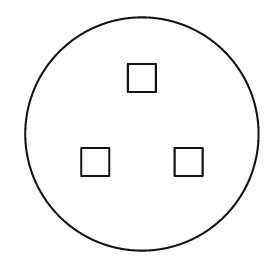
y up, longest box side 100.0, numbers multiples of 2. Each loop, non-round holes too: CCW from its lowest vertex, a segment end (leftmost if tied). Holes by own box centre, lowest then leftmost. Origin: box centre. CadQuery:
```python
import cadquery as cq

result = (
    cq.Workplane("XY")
    .moveTo(0.0, 0.0)
    .circle(50.0)
    .moveTo(-26.0, -18.0)
    .lineTo(-14.0, -18.0)
    .lineTo(-14.0, -6.0)
    .lineTo(-26.0, -6.0)
    .close()
    .moveTo(14.0, -18.0)
    .lineTo(26.0, -18.0)
    .lineTo(26.0, -6.0)
    .lineTo(14.0, -6.0)
    .close()
    .moveTo(-6.0, 18.0)
    .lineTo(6.0, 18.0)
    .lineTo(6.0, 30.0)
    .lineTo(-6.0, 30.0)
    .close()
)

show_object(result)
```